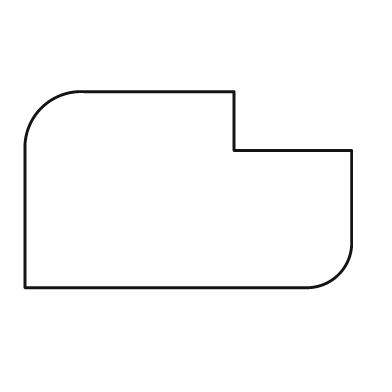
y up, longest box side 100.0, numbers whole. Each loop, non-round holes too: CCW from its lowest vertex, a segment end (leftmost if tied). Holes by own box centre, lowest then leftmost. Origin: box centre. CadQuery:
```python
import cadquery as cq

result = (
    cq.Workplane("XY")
    .moveTo(-50.0, -30.0)
    .lineTo(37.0, -30.0)
    .threePointArc((46.0, -26.0), (50.0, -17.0))
    .lineTo(50.0, 12.0)
    .lineTo(14.0, 12.0)
    .lineTo(14.0, 30.0)
    .lineTo(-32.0, 30.0)
    .threePointArc((-45.0, 25.0), (-50.0, 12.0))
    .close()
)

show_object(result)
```